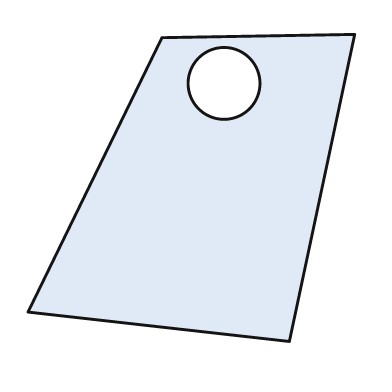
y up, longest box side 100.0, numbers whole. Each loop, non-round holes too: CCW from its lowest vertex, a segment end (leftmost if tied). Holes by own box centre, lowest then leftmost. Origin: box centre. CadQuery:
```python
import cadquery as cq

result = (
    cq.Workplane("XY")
    .moveTo(30.0, -47.0)
    .lineTo(50.0, 47.0)
    .lineTo(-9.0, 46.0)
    .lineTo(-50.0, -38.0)
    .close()
    .moveTo(10.0, 32.0)
    .circle(11.0)
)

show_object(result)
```